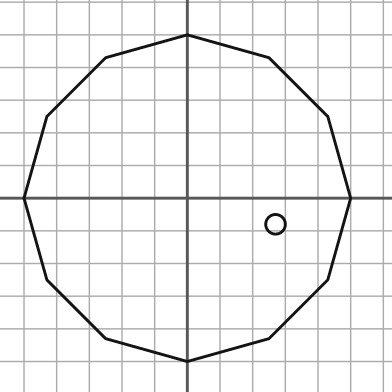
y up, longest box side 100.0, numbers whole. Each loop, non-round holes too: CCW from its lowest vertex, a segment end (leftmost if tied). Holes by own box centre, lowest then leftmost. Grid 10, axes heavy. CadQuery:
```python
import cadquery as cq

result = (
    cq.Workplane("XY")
    .moveTo(0.0, -50.0)
    .lineTo(25.0, -43.0)
    .lineTo(43.0, -25.0)
    .lineTo(50.0, 0.0)
    .lineTo(43.0, 25.0)
    .lineTo(25.0, 43.0)
    .lineTo(0.0, 50.0)
    .lineTo(-25.0, 43.0)
    .lineTo(-43.0, 25.0)
    .lineTo(-50.0, 0.0)
    .lineTo(-43.0, -25.0)
    .lineTo(-25.0, -43.0)
    .close()
    .moveTo(27.0, -8.0)
    .circle(3.0)
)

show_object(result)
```